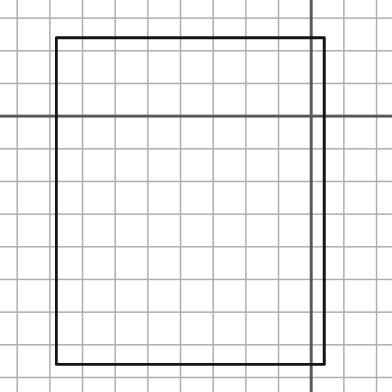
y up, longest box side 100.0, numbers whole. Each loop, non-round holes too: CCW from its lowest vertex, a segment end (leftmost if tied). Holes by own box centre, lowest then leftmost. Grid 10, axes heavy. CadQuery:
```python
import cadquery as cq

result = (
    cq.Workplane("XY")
    .moveTo(-78.0, -76.0)
    .lineTo(4.0, -76.0)
    .lineTo(4.0, 24.0)
    .lineTo(-78.0, 24.0)
    .close()
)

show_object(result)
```